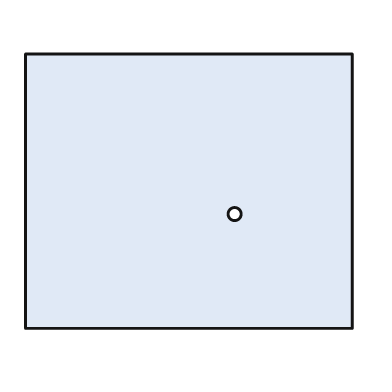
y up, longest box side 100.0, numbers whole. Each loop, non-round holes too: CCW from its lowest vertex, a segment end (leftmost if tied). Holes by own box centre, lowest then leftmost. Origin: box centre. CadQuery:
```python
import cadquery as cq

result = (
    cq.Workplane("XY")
    .moveTo(-50.0, -42.0)
    .lineTo(50.0, -42.0)
    .lineTo(50.0, 42.0)
    .lineTo(-50.0, 42.0)
    .close()
    .moveTo(14.0, -7.0)
    .circle(2.0)
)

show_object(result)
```